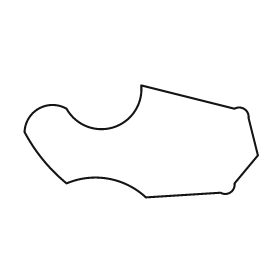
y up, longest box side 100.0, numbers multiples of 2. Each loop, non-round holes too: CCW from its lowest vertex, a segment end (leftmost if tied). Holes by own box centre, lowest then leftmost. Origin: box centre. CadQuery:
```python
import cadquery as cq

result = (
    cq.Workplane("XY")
    .moveTo(2.0, -24.0)
    .lineTo(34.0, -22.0)
    .threePointArc((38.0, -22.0), (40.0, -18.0))
    .lineTo(50.0, -6.0)
    .lineTo(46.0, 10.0)
    .threePointArc((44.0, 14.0), (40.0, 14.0))
    .lineTo(0.0, 24.0)
    .threePointArc((-12.0, 6.0), (-32.0, 14.0))
    .threePointArc((-44.0, 14.0), (-50.0, 4.0))
    .threePointArc((-42.0, -8.0), (-32.0, -18.0))
    .threePointArc((-14.0, -16.0), (2.0, -24.0))
    .close()
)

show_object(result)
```